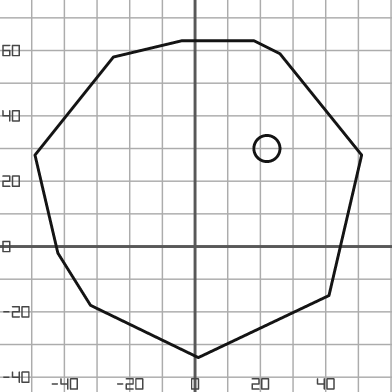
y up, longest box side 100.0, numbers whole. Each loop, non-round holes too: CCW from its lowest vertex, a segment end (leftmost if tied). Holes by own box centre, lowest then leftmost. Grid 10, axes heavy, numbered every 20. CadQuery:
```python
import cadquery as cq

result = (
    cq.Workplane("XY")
    .moveTo(1.0, -34.0)
    .lineTo(41.0, -15.0)
    .lineTo(51.0, 28.0)
    .lineTo(26.0, 59.0)
    .lineTo(18.0, 63.0)
    .lineTo(-4.0, 63.0)
    .lineTo(-25.0, 58.0)
    .lineTo(-49.0, 28.0)
    .lineTo(-42.0, -2.0)
    .lineTo(-32.0, -18.0)
    .close()
    .moveTo(22.0, 30.0)
    .circle(4.0)
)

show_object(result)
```